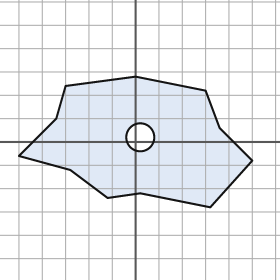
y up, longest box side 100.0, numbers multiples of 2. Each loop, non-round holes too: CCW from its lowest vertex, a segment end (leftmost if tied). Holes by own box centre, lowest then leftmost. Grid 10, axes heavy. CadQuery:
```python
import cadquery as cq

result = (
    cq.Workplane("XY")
    .moveTo(32.0, -28.0)
    .lineTo(50.0, -8.0)
    .lineTo(36.0, 6.0)
    .lineTo(30.0, 22.0)
    .lineTo(0.0, 28.0)
    .lineTo(-30.0, 24.0)
    .lineTo(-34.0, 10.0)
    .lineTo(-50.0, -6.0)
    .lineTo(-28.0, -12.0)
    .lineTo(-12.0, -24.0)
    .lineTo(2.0, -22.0)
    .close()
    .moveTo(2.0, 2.0)
    .circle(6.0)
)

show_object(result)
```